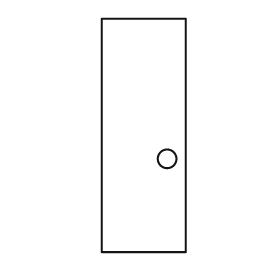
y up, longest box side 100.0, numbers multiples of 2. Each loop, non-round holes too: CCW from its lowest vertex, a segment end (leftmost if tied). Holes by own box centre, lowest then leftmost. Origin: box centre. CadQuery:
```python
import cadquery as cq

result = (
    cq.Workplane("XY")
    .moveTo(-18.0, -50.0)
    .lineTo(18.0, -50.0)
    .lineTo(18.0, 50.0)
    .lineTo(-18.0, 50.0)
    .close()
    .moveTo(10.0, -10.0)
    .circle(4.0)
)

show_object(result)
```